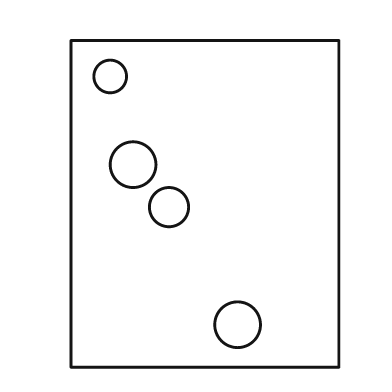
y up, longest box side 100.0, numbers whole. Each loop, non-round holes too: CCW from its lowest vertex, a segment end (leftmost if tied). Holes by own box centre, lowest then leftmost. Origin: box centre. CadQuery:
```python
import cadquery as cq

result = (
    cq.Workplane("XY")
    .moveTo(-41.0, -50.0)
    .lineTo(41.0, -50.0)
    .lineTo(41.0, 50.0)
    .lineTo(-41.0, 50.0)
    .close()
    .moveTo(10.0, -37.0)
    .circle(7.0)
    .moveTo(-11.0, -1.0)
    .circle(6.0)
    .moveTo(-22.0, 12.0)
    .circle(7.0)
    .moveTo(-29.0, 39.0)
    .circle(5.0)
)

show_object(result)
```